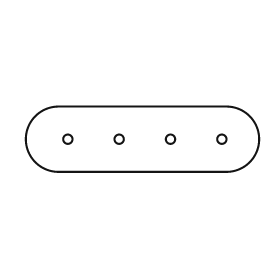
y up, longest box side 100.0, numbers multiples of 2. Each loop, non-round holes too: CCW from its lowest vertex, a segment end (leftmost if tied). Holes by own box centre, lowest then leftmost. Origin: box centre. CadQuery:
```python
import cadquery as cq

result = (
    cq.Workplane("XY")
    .moveTo(-36.0, -14.0)
    .lineTo(36.0, -14.0)
    .threePointArc((50.0, 0.0), (36.0, 14.0))
    .lineTo(-36.0, 14.0)
    .threePointArc((-50.0, 0.0), (-36.0, -14.0))
    .close()
    .moveTo(-32.0, 0.0)
    .circle(2.0)
    .moveTo(-10.0, 0.0)
    .circle(2.0)
    .moveTo(12.0, 0.0)
    .circle(2.0)
    .moveTo(34.0, 0.0)
    .circle(2.0)
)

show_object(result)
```